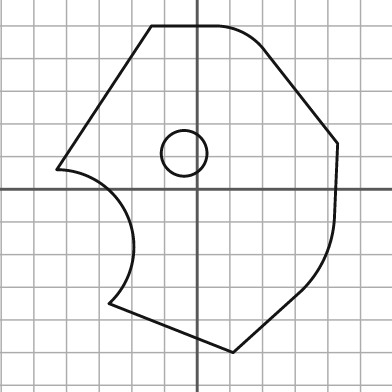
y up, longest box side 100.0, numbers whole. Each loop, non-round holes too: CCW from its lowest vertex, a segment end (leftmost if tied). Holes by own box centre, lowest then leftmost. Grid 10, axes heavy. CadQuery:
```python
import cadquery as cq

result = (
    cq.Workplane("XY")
    .moveTo(11.0, -50.0)
    .lineTo(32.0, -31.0)
    .threePointArc((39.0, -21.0), (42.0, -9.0))
    .lineTo(43.0, 14.0)
    .lineTo(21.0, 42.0)
    .threePointArc((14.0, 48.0), (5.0, 50.0))
    .lineTo(-14.0, 50.0)
    .lineTo(-43.0, 6.0)
    .threePointArc((-21.0, -9.0), (-27.0, -35.0))
    .close()
    .moveTo(-4.0, 11.0)
    .circle(7.0)
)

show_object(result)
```